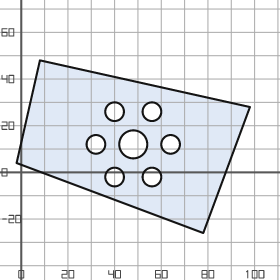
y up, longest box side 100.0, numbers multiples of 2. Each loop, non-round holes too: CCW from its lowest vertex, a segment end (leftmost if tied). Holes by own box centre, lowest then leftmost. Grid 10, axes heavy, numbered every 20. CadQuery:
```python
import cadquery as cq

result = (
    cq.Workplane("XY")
    .moveTo(78.0, -26.0)
    .lineTo(98.0, 28.0)
    .lineTo(8.0, 48.0)
    .lineTo(-2.0, 4.0)
    .close()
    .moveTo(40.0, -2.0)
    .circle(4.0)
    .moveTo(56.0, -2.0)
    .circle(4.0)
    .moveTo(32.0, 12.0)
    .circle(4.0)
    .moveTo(48.0, 12.0)
    .circle(6.0)
    .moveTo(64.0, 12.0)
    .circle(4.0)
    .moveTo(40.0, 26.0)
    .circle(4.0)
    .moveTo(56.0, 26.0)
    .circle(4.0)
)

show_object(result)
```